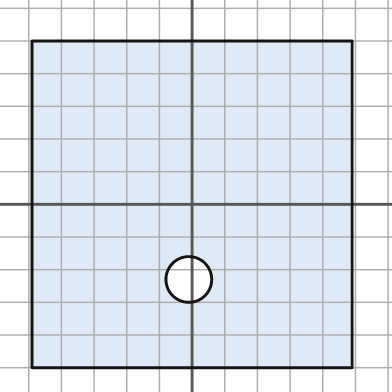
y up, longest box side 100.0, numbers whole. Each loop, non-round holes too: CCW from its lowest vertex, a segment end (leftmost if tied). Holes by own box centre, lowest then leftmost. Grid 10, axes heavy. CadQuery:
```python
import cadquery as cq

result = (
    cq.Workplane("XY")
    .moveTo(-49.0, -50.0)
    .lineTo(49.0, -50.0)
    .lineTo(49.0, 50.0)
    .lineTo(-49.0, 50.0)
    .close()
    .moveTo(-1.0, -23.0)
    .circle(7.0)
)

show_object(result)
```